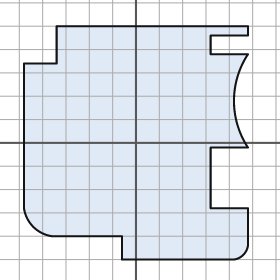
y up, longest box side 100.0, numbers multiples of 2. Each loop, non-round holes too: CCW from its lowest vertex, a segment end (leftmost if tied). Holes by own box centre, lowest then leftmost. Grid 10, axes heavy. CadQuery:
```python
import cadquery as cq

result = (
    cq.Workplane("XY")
    .moveTo(-6.0, -50.0)
    .lineTo(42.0, -50.0)
    .threePointArc((46.0, -48.0), (48.0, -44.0))
    .lineTo(48.0, -28.0)
    .lineTo(32.0, -28.0)
    .lineTo(32.0, -2.0)
    .lineTo(48.0, -2.0)
    .threePointArc((42.0, 18.0), (48.0, 38.0))
    .lineTo(32.0, 38.0)
    .lineTo(32.0, 46.0)
    .lineTo(48.0, 46.0)
    .lineTo(48.0, 50.0)
    .lineTo(-34.0, 50.0)
    .lineTo(-34.0, 34.0)
    .lineTo(-48.0, 34.0)
    .lineTo(-48.0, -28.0)
    .threePointArc((-44.0, -36.0), (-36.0, -40.0))
    .lineTo(-6.0, -40.0)
    .close()
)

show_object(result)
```